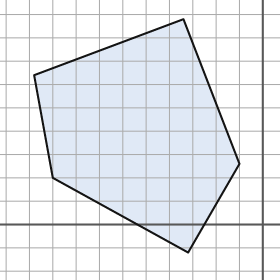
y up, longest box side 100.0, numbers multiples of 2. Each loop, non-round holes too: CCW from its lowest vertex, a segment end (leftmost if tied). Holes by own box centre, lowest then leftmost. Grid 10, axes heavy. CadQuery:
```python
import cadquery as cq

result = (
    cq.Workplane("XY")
    .moveTo(-32.0, -12.0)
    .lineTo(-10.0, 26.0)
    .lineTo(-34.0, 88.0)
    .lineTo(-98.0, 64.0)
    .lineTo(-90.0, 20.0)
    .close()
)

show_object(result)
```